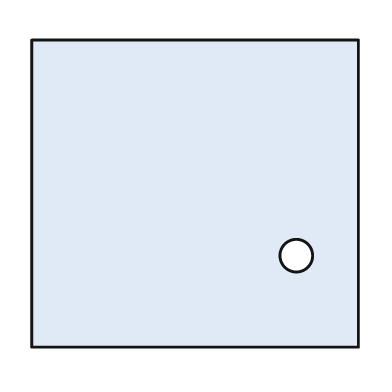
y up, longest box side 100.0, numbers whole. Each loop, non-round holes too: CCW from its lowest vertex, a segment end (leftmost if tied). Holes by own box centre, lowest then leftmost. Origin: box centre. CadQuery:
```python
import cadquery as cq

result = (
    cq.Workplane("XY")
    .moveTo(-50.0, -47.0)
    .lineTo(50.0, -47.0)
    .lineTo(50.0, 47.0)
    .lineTo(-50.0, 47.0)
    .close()
    .moveTo(31.0, -19.0)
    .circle(5.0)
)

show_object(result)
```